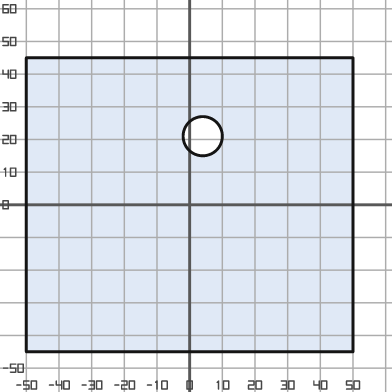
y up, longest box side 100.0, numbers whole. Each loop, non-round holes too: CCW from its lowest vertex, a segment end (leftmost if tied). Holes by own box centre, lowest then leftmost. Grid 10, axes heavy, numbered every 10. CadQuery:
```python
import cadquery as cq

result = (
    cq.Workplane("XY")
    .moveTo(-50.0, -45.0)
    .lineTo(50.0, -45.0)
    .lineTo(50.0, 45.0)
    .lineTo(-50.0, 45.0)
    .close()
    .moveTo(4.0, 21.0)
    .circle(6.0)
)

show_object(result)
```